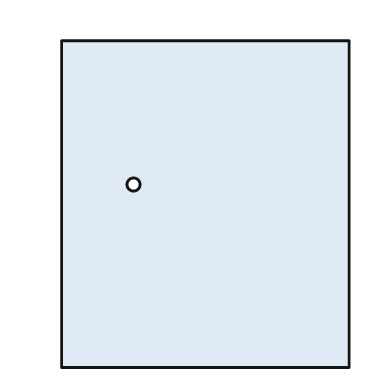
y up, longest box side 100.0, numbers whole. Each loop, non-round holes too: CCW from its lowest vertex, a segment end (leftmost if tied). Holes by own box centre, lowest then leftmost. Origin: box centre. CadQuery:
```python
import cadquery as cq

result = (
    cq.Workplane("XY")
    .moveTo(-44.0, -50.0)
    .lineTo(44.0, -50.0)
    .lineTo(44.0, 50.0)
    .lineTo(-44.0, 50.0)
    .close()
    .moveTo(-22.0, 6.0)
    .circle(2.0)
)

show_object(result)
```